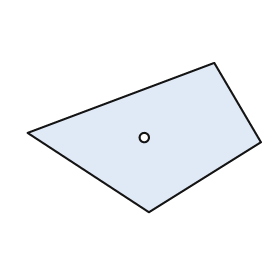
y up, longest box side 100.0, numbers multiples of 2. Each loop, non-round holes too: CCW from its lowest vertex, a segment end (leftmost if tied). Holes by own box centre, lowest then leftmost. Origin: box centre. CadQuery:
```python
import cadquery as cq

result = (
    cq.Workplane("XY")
    .moveTo(2.0, -32.0)
    .lineTo(50.0, -2.0)
    .lineTo(30.0, 32.0)
    .lineTo(-50.0, 2.0)
    .close()
    .moveTo(0.0, 0.0)
    .circle(2.0)
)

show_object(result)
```